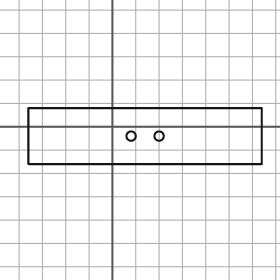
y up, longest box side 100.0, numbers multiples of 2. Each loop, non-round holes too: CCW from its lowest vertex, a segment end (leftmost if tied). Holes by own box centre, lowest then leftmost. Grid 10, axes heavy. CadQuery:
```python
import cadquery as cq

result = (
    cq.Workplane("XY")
    .moveTo(-36.0, -16.0)
    .lineTo(64.0, -16.0)
    .lineTo(64.0, 8.0)
    .lineTo(-36.0, 8.0)
    .close()
    .moveTo(8.0, -4.0)
    .circle(2.0)
    .moveTo(20.0, -4.0)
    .circle(2.0)
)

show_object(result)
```